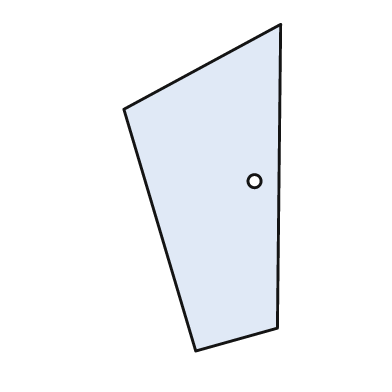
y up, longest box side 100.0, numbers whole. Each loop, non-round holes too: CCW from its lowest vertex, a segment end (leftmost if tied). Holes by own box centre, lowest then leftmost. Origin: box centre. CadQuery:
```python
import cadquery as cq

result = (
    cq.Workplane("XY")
    .moveTo(-2.0, -50.0)
    .lineTo(23.0, -43.0)
    .lineTo(24.0, 50.0)
    .lineTo(-24.0, 24.0)
    .close()
    .moveTo(16.0, 2.0)
    .circle(2.0)
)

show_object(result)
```